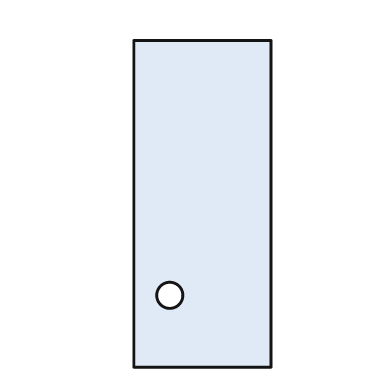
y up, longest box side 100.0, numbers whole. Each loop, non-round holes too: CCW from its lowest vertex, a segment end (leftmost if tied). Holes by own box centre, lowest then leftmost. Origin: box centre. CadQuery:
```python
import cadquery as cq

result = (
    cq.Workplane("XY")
    .moveTo(-21.0, -50.0)
    .lineTo(21.0, -50.0)
    .lineTo(21.0, 50.0)
    .lineTo(-21.0, 50.0)
    .close()
    .moveTo(-10.0, -28.0)
    .circle(4.0)
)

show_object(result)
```